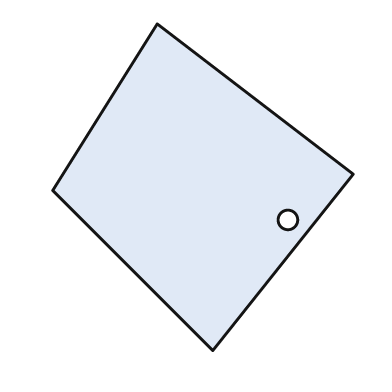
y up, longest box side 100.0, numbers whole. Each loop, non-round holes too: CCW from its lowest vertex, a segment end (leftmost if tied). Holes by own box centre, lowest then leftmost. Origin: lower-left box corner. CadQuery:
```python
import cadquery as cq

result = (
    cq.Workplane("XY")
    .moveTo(49.0, 0.0)
    .lineTo(92.0, 54.0)
    .lineTo(32.0, 100.0)
    .lineTo(0.0, 49.0)
    .close()
    .moveTo(72.0, 40.0)
    .circle(3.0)
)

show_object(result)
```